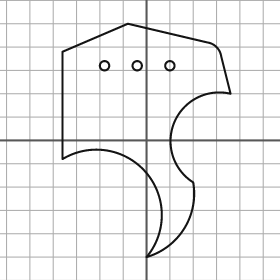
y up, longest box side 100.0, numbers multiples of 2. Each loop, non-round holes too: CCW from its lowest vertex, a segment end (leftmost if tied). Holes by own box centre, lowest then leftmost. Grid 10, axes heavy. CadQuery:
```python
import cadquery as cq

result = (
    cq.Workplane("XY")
    .moveTo(0.0, -50.0)
    .threePointArc((16.0, -38.0), (20.0, -18.0))
    .threePointArc((12.0, 8.0), (36.0, 20.0))
    .lineTo(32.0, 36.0)
    .threePointArc((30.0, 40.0), (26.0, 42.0))
    .lineTo(-8.0, 50.0)
    .lineTo(-36.0, 38.0)
    .lineTo(-36.0, -8.0)
    .threePointArc((0.0, -14.0), (0.0, -50.0))
    .close()
    .moveTo(-18.0, 32.0)
    .circle(2.0)
    .moveTo(-4.0, 32.0)
    .circle(2.0)
    .moveTo(10.0, 32.0)
    .circle(2.0)
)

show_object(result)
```